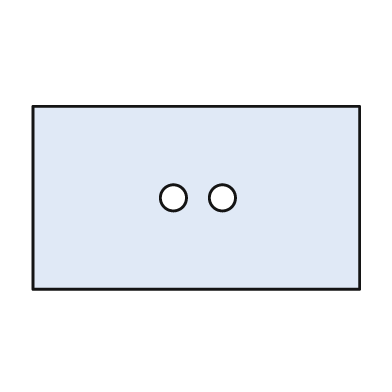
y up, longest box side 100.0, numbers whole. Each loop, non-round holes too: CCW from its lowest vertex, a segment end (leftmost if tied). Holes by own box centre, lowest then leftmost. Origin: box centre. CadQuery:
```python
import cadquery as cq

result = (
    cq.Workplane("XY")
    .moveTo(-50.0, -28.0)
    .lineTo(50.0, -28.0)
    .lineTo(50.0, 28.0)
    .lineTo(-50.0, 28.0)
    .close()
    .moveTo(-7.0, 0.0)
    .circle(4.0)
    .moveTo(8.0, 0.0)
    .circle(4.0)
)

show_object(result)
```